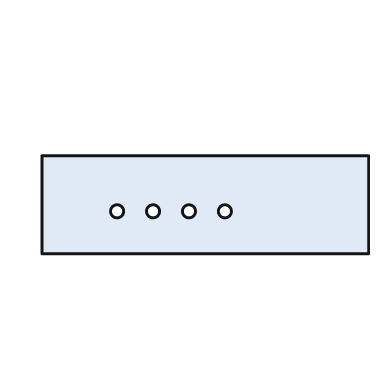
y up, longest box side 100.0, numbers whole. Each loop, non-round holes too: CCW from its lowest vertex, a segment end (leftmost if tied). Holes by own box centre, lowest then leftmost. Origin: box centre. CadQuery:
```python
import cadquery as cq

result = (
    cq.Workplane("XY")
    .moveTo(-50.0, -15.0)
    .lineTo(50.0, -15.0)
    .lineTo(50.0, 15.0)
    .lineTo(-50.0, 15.0)
    .close()
    .moveTo(-27.0, -2.0)
    .circle(2.0)
    .moveTo(-16.0, -2.0)
    .circle(2.0)
    .moveTo(-5.0, -2.0)
    .circle(2.0)
    .moveTo(6.0, -2.0)
    .circle(2.0)
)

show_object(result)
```